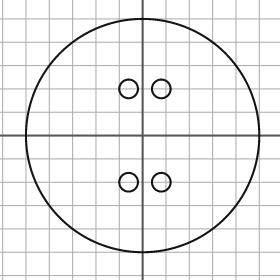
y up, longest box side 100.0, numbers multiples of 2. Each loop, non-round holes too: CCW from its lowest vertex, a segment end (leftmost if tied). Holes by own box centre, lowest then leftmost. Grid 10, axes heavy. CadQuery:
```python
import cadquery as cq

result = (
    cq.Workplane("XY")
    .moveTo(0.0, 0.0)
    .circle(50.0)
    .moveTo(-6.0, -20.0)
    .circle(4.0)
    .moveTo(8.0, -20.0)
    .circle(4.0)
    .moveTo(-6.0, 20.0)
    .circle(4.0)
    .moveTo(8.0, 20.0)
    .circle(4.0)
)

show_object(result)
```